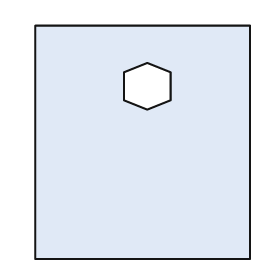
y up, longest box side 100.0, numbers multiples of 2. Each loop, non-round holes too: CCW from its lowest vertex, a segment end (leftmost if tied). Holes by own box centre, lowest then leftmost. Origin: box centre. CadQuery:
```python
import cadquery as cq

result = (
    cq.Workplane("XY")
    .moveTo(-46.0, -50.0)
    .lineTo(46.0, -50.0)
    .lineTo(46.0, 50.0)
    .lineTo(-46.0, 50.0)
    .close()
    .moveTo(2.0, 14.0)
    .lineTo(12.0, 18.0)
    .lineTo(12.0, 30.0)
    .lineTo(2.0, 34.0)
    .lineTo(-8.0, 30.0)
    .lineTo(-8.0, 18.0)
    .close()
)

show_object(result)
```